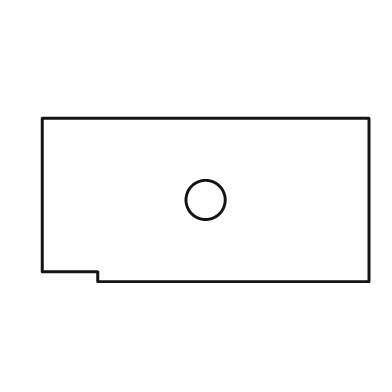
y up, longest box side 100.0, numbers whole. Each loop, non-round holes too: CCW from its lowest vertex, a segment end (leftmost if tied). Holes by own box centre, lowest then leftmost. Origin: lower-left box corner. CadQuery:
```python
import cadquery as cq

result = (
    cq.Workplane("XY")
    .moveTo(17.0, 0.0)
    .lineTo(100.0, 0.0)
    .lineTo(100.0, 50.0)
    .lineTo(0.0, 50.0)
    .lineTo(0.0, 3.0)
    .lineTo(17.0, 3.0)
    .close()
    .moveTo(50.0, 25.0)
    .circle(6.0)
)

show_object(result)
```